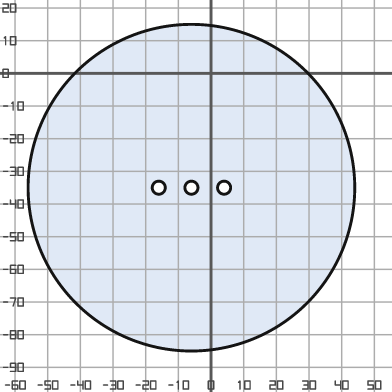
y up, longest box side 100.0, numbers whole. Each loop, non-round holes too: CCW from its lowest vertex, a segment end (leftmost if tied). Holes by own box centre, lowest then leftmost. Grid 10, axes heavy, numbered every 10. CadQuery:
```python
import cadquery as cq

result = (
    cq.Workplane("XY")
    .moveTo(-6.0, -35.0)
    .circle(50.0)
    .moveTo(-16.0, -35.0)
    .circle(2.0)
    .moveTo(-6.0, -35.0)
    .circle(2.0)
    .moveTo(4.0, -35.0)
    .circle(2.0)
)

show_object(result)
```